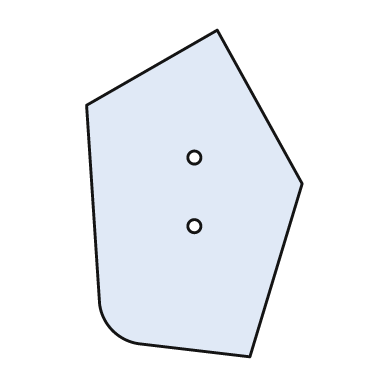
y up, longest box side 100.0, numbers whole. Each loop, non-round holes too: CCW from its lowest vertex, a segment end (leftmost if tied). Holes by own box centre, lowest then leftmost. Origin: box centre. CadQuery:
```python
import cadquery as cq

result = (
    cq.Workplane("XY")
    .moveTo(17.0, -50.0)
    .lineTo(33.0, 3.0)
    .lineTo(7.0, 50.0)
    .lineTo(-33.0, 27.0)
    .lineTo(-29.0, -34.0)
    .threePointArc((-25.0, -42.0), (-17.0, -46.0))
    .close()
    .moveTo(0.0, -10.0)
    .circle(2.0)
    .moveTo(0.0, 11.0)
    .circle(2.0)
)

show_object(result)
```